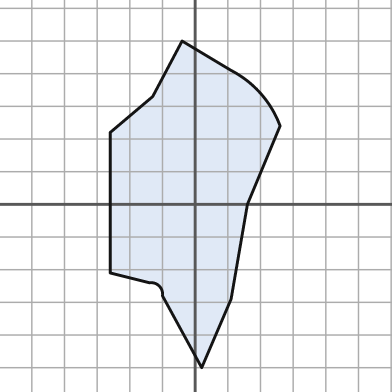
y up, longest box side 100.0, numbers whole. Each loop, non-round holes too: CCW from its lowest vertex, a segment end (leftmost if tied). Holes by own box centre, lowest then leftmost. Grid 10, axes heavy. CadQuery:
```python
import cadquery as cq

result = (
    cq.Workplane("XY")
    .moveTo(2.0, -50.0)
    .lineTo(11.0, -29.0)
    .lineTo(16.0, 0.0)
    .lineTo(26.0, 24.0)
    .threePointArc((20.0, 34.0), (11.0, 41.0))
    .lineTo(-4.0, 50.0)
    .lineTo(-13.0, 33.0)
    .lineTo(-26.0, 22.0)
    .lineTo(-26.0, -21.0)
    .lineTo(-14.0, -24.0)
    .threePointArc((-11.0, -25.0), (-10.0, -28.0))
    .close()
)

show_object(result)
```